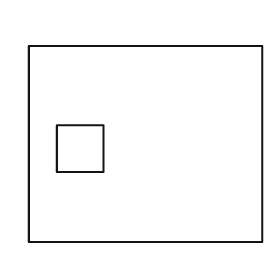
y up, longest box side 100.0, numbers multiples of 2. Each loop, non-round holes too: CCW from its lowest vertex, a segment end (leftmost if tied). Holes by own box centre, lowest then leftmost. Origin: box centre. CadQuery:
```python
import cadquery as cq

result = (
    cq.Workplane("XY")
    .moveTo(-50.0, -42.0)
    .lineTo(50.0, -42.0)
    .lineTo(50.0, 42.0)
    .lineTo(-50.0, 42.0)
    .close()
    .moveTo(-38.0, -12.0)
    .lineTo(-18.0, -12.0)
    .lineTo(-18.0, 8.0)
    .lineTo(-38.0, 8.0)
    .close()
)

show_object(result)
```